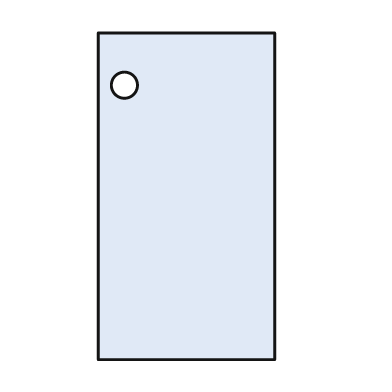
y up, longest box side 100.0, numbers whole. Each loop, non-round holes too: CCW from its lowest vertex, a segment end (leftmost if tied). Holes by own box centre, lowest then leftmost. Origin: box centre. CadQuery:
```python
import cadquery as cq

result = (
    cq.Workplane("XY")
    .moveTo(-27.0, -50.0)
    .lineTo(27.0, -50.0)
    .lineTo(27.0, 50.0)
    .lineTo(-27.0, 50.0)
    .close()
    .moveTo(-19.0, 34.0)
    .circle(4.0)
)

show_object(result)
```